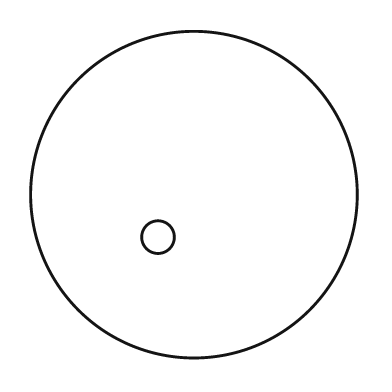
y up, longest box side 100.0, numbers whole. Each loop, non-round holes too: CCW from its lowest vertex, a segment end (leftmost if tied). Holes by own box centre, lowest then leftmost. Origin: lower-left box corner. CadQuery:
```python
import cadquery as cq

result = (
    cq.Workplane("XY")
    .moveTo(50.0, 50.0)
    .circle(50.0)
    .moveTo(39.0, 37.0)
    .circle(5.0)
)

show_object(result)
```